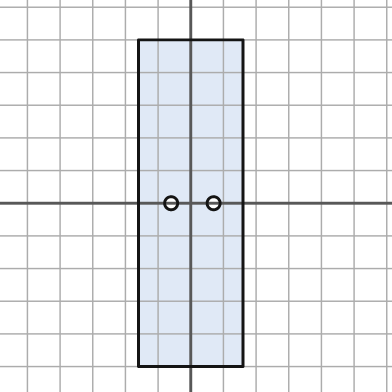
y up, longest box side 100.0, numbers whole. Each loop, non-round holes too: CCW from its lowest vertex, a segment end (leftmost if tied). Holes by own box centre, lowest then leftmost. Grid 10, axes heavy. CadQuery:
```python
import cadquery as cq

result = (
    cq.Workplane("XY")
    .moveTo(-16.0, -50.0)
    .lineTo(16.0, -50.0)
    .lineTo(16.0, 50.0)
    .lineTo(-16.0, 50.0)
    .close()
    .moveTo(-6.0, 0.0)
    .circle(2.0)
    .moveTo(7.0, 0.0)
    .circle(2.0)
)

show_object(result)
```